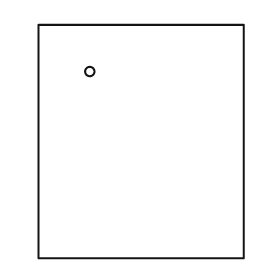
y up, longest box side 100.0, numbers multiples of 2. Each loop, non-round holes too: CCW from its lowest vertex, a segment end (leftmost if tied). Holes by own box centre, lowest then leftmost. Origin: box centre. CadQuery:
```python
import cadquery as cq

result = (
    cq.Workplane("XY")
    .moveTo(-44.0, -50.0)
    .lineTo(44.0, -50.0)
    .lineTo(44.0, 50.0)
    .lineTo(-44.0, 50.0)
    .close()
    .moveTo(-22.0, 30.0)
    .circle(2.0)
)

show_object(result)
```